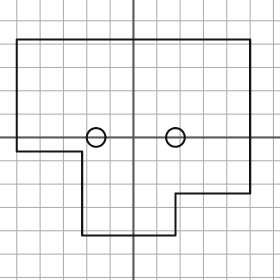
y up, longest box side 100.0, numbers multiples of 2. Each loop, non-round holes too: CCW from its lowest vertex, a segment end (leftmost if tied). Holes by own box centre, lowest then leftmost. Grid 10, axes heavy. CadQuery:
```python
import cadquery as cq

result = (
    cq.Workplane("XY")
    .moveTo(-22.0, -42.0)
    .lineTo(18.0, -42.0)
    .lineTo(18.0, -24.0)
    .lineTo(50.0, -24.0)
    .lineTo(50.0, 42.0)
    .lineTo(-50.0, 42.0)
    .lineTo(-50.0, -6.0)
    .lineTo(-22.0, -6.0)
    .close()
    .moveTo(-16.0, 0.0)
    .circle(4.0)
    .moveTo(18.0, 0.0)
    .circle(4.0)
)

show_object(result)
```